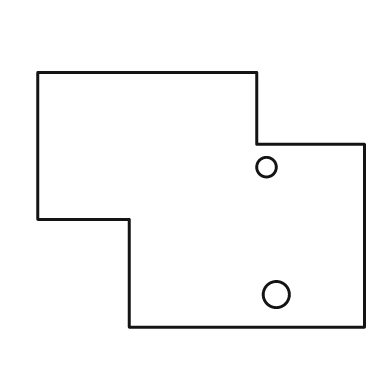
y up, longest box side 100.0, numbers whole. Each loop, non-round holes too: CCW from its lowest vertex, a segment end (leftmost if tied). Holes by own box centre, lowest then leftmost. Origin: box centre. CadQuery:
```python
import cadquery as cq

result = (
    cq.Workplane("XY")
    .moveTo(-22.0, -39.0)
    .lineTo(50.0, -39.0)
    .lineTo(50.0, 17.0)
    .lineTo(17.0, 17.0)
    .lineTo(17.0, 39.0)
    .lineTo(-50.0, 39.0)
    .lineTo(-50.0, -6.0)
    .lineTo(-22.0, -6.0)
    .close()
    .moveTo(23.0, -29.0)
    .circle(4.0)
    .moveTo(20.0, 10.0)
    .circle(3.0)
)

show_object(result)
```